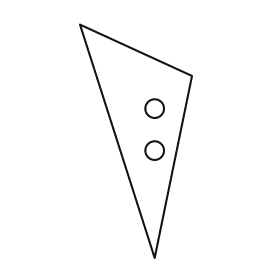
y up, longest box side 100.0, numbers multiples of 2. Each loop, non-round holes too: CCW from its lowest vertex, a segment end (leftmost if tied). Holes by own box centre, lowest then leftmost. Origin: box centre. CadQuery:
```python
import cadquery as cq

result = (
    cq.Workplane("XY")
    .moveTo(8.0, -50.0)
    .lineTo(24.0, 28.0)
    .lineTo(-24.0, 50.0)
    .close()
    .moveTo(8.0, -4.0)
    .circle(4.0)
    .moveTo(8.0, 14.0)
    .circle(4.0)
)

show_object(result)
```